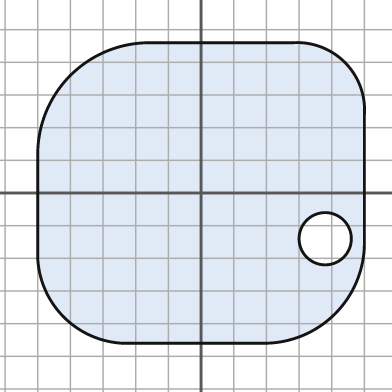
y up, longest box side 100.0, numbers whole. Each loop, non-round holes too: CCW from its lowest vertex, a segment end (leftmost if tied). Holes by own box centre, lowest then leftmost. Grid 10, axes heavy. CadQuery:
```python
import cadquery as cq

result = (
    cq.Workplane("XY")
    .moveTo(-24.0, -46.0)
    .lineTo(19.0, -46.0)
    .threePointArc((41.0, -37.0), (50.0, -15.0))
    .lineTo(50.0, 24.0)
    .threePointArc((44.0, 40.0), (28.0, 46.0))
    .lineTo(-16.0, 46.0)
    .threePointArc((-40.0, 36.0), (-50.0, 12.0))
    .lineTo(-50.0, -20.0)
    .threePointArc((-42.0, -38.0), (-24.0, -46.0))
    .close()
    .moveTo(38.0, -14.0)
    .circle(8.0)
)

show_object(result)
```